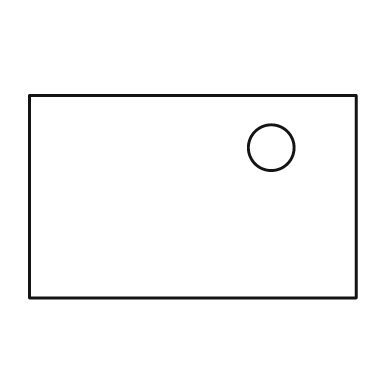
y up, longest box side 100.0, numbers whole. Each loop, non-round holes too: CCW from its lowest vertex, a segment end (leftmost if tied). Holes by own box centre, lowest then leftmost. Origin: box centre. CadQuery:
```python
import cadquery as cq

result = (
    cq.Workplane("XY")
    .moveTo(-50.0, -31.0)
    .lineTo(50.0, -31.0)
    .lineTo(50.0, 31.0)
    .lineTo(-50.0, 31.0)
    .close()
    .moveTo(24.0, 15.0)
    .circle(7.0)
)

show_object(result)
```